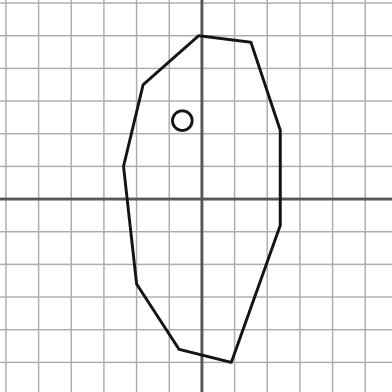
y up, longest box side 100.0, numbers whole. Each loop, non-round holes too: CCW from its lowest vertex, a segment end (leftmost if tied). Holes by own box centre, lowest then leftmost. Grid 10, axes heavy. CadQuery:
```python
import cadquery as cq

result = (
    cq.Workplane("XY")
    .moveTo(9.0, -50.0)
    .lineTo(24.0, -8.0)
    .lineTo(24.0, 21.0)
    .lineTo(15.0, 48.0)
    .lineTo(-1.0, 50.0)
    .lineTo(-18.0, 35.0)
    .lineTo(-24.0, 10.0)
    .lineTo(-20.0, -26.0)
    .lineTo(-7.0, -46.0)
    .close()
    .moveTo(-6.0, 24.0)
    .circle(3.0)
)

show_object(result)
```